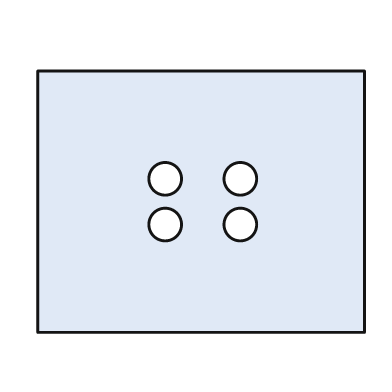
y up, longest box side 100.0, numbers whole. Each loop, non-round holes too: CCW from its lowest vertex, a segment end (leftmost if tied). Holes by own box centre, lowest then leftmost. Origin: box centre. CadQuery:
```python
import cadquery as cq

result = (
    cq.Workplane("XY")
    .moveTo(-50.0, -40.0)
    .lineTo(50.0, -40.0)
    .lineTo(50.0, 40.0)
    .lineTo(-50.0, 40.0)
    .close()
    .moveTo(-11.0, -7.0)
    .circle(5.0)
    .moveTo(12.0, -7.0)
    .circle(5.0)
    .moveTo(-11.0, 7.0)
    .circle(5.0)
    .moveTo(12.0, 7.0)
    .circle(5.0)
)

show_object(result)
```